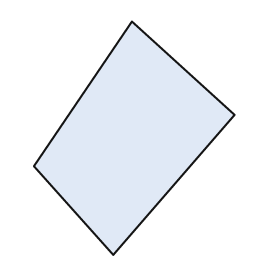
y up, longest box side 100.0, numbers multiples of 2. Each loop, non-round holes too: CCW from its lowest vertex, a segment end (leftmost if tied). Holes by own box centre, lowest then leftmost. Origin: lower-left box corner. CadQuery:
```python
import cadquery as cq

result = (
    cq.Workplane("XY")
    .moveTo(34.0, 0.0)
    .lineTo(86.0, 60.0)
    .lineTo(42.0, 100.0)
    .lineTo(0.0, 38.0)
    .close()
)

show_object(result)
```